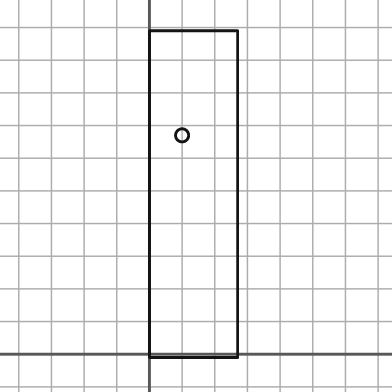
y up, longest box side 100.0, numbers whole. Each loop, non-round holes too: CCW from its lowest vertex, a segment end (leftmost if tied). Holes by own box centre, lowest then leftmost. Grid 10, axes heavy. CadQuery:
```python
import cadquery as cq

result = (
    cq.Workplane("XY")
    .moveTo(0.0, -1.0)
    .lineTo(27.0, -1.0)
    .lineTo(27.0, 99.0)
    .lineTo(0.0, 99.0)
    .close()
    .moveTo(10.0, 67.0)
    .circle(2.0)
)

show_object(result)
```